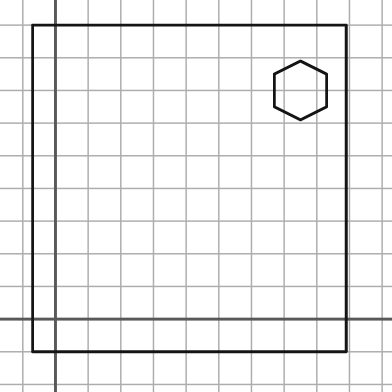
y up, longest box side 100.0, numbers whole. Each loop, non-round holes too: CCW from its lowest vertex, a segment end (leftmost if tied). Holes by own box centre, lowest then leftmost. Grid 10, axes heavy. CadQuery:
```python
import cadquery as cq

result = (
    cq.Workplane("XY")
    .moveTo(-7.0, -10.0)
    .lineTo(89.0, -10.0)
    .lineTo(89.0, 90.0)
    .lineTo(-7.0, 90.0)
    .close()
    .moveTo(75.0, 61.0)
    .lineTo(83.0, 65.0)
    .lineTo(83.0, 75.0)
    .lineTo(75.0, 79.0)
    .lineTo(67.0, 75.0)
    .lineTo(67.0, 65.0)
    .close()
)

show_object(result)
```